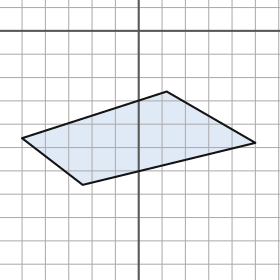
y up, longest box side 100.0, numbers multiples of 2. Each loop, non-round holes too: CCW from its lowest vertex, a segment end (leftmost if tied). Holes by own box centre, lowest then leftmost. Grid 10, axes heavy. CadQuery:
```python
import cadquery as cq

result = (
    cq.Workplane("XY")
    .moveTo(-24.0, -66.0)
    .lineTo(50.0, -48.0)
    .lineTo(12.0, -26.0)
    .lineTo(-50.0, -46.0)
    .close()
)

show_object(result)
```